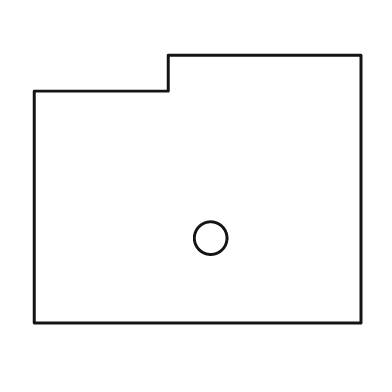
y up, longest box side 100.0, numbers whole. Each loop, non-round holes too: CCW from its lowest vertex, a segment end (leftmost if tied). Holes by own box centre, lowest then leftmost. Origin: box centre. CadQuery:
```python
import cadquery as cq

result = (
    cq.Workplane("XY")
    .moveTo(-50.0, -41.0)
    .lineTo(50.0, -41.0)
    .lineTo(50.0, 41.0)
    .lineTo(-9.0, 41.0)
    .lineTo(-9.0, 30.0)
    .lineTo(-50.0, 30.0)
    .close()
    .moveTo(4.0, -15.0)
    .circle(5.0)
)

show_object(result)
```